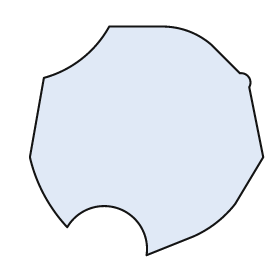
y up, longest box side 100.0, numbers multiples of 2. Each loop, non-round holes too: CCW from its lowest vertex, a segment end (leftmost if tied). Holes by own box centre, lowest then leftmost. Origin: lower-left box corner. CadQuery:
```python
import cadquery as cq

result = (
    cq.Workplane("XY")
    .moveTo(50.0, 0.0)
    .lineTo(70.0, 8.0)
    .threePointArc((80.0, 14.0), (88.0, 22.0))
    .lineTo(100.0, 42.0)
    .lineTo(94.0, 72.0)
    .threePointArc((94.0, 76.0), (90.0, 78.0))
    .lineTo(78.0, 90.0)
    .threePointArc((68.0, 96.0), (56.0, 98.0))
    .lineTo(34.0, 98.0)
    .threePointArc((22.0, 84.0), (6.0, 76.0))
    .lineTo(0.0, 42.0)
    .threePointArc((6.0, 26.0), (16.0, 12.0))
    .threePointArc((38.0, 20.0), (50.0, 0.0))
    .close()
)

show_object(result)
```